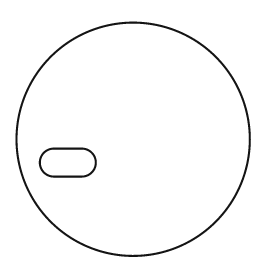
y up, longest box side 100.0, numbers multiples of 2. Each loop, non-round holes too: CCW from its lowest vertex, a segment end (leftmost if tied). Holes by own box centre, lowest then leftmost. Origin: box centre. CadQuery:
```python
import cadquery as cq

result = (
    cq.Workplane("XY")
    .moveTo(0.0, 0.0)
    .circle(50.0)
    .moveTo(-34.0, -16.0)
    .lineTo(-22.0, -16.0)
    .threePointArc((-16.0, -10.0), (-22.0, -4.0))
    .lineTo(-34.0, -4.0)
    .threePointArc((-40.0, -10.0), (-34.0, -16.0))
    .close()
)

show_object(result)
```